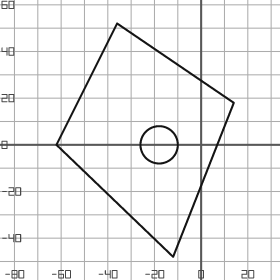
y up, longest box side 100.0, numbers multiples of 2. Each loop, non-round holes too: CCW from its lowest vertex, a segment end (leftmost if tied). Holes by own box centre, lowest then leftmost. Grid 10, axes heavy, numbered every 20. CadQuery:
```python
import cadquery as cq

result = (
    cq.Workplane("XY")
    .moveTo(-12.0, -48.0)
    .lineTo(14.0, 18.0)
    .lineTo(-36.0, 52.0)
    .lineTo(-62.0, 0.0)
    .close()
    .moveTo(-18.0, 0.0)
    .circle(8.0)
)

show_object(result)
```